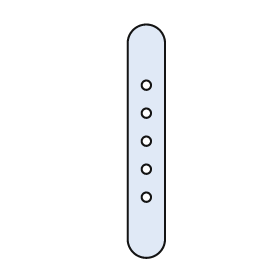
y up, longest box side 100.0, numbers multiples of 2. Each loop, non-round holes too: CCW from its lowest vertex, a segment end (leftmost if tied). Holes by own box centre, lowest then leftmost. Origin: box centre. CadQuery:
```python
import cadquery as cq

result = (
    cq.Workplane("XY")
    .moveTo(-8.0, -42.0)
    .threePointArc((0.0, -50.0), (8.0, -42.0))
    .lineTo(8.0, 42.0)
    .threePointArc((0.0, 50.0), (-8.0, 42.0))
    .close()
    .moveTo(0.0, -24.0)
    .circle(2.0)
    .moveTo(0.0, -12.0)
    .circle(2.0)
    .moveTo(0.0, 0.0)
    .circle(2.0)
    .moveTo(0.0, 12.0)
    .circle(2.0)
    .moveTo(0.0, 24.0)
    .circle(2.0)
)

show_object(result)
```